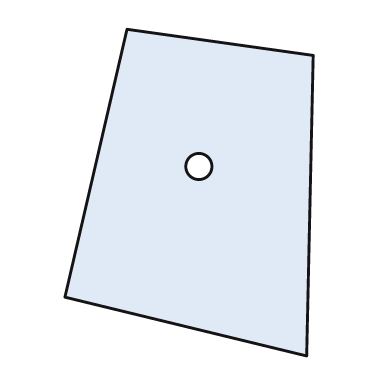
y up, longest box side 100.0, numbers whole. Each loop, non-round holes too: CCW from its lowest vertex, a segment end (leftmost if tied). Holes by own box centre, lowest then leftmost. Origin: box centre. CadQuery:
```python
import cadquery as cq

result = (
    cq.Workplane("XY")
    .moveTo(36.0, -50.0)
    .lineTo(38.0, 42.0)
    .lineTo(-19.0, 50.0)
    .lineTo(-38.0, -32.0)
    .close()
    .moveTo(3.0, 8.0)
    .circle(4.0)
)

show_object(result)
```